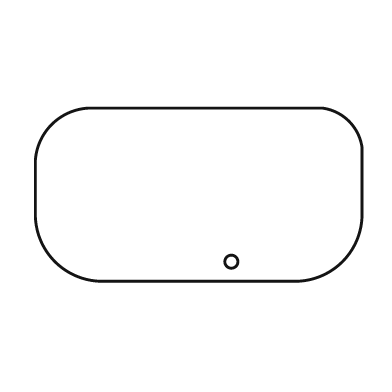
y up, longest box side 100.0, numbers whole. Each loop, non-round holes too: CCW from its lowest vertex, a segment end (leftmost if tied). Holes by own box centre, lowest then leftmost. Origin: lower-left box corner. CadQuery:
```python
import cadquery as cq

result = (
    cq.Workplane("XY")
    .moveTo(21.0, 0.0)
    .lineTo(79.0, 0.0)
    .threePointArc((94.0, 6.0), (100.0, 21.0))
    .lineTo(100.0, 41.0)
    .threePointArc((96.0, 49.0), (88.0, 53.0))
    .lineTo(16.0, 53.0)
    .threePointArc((5.0, 48.0), (0.0, 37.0))
    .lineTo(0.0, 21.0)
    .threePointArc((6.0, 6.0), (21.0, 0.0))
    .close()
    .moveTo(60.0, 6.0)
    .circle(2.0)
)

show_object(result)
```